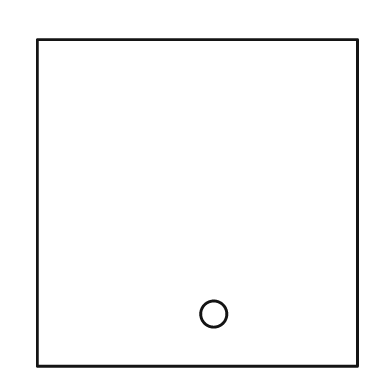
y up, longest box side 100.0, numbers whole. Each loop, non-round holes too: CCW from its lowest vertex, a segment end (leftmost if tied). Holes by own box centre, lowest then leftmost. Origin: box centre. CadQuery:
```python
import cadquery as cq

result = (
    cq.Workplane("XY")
    .moveTo(-49.0, -50.0)
    .lineTo(49.0, -50.0)
    .lineTo(49.0, 50.0)
    .lineTo(-49.0, 50.0)
    .close()
    .moveTo(5.0, -34.0)
    .circle(4.0)
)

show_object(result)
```